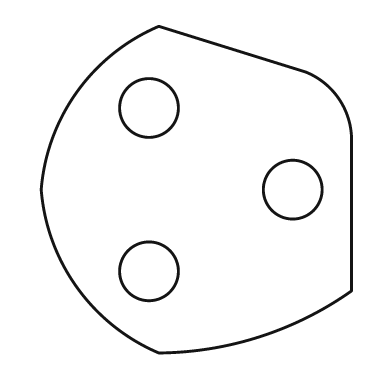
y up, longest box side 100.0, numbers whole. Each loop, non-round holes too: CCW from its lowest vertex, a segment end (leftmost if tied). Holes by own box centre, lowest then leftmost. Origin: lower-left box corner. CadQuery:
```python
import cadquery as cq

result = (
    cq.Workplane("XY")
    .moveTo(36.0, 0.0)
    .threePointArc((67.0, 5.0), (95.0, 19.0))
    .lineTo(95.0, 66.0)
    .threePointArc((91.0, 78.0), (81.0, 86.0))
    .lineTo(36.0, 100.0)
    .threePointArc((11.0, 80.0), (0.0, 50.0))
    .threePointArc((11.0, 20.0), (36.0, 0.0))
    .close()
    .moveTo(33.0, 25.0)
    .circle(9.0)
    .moveTo(77.0, 50.0)
    .circle(9.0)
    .moveTo(33.0, 75.0)
    .circle(9.0)
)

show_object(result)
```